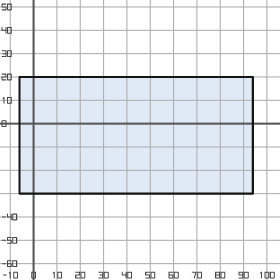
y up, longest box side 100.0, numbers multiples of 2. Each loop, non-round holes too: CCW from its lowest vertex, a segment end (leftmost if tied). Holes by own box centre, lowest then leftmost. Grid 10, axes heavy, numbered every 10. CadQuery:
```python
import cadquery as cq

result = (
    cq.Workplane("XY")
    .moveTo(-6.0, -30.0)
    .lineTo(94.0, -30.0)
    .lineTo(94.0, 20.0)
    .lineTo(-6.0, 20.0)
    .close()
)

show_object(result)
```